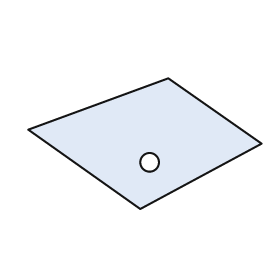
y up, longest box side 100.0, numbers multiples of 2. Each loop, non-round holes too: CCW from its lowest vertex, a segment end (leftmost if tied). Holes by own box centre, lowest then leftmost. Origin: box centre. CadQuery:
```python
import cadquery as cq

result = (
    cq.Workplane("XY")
    .moveTo(-2.0, -28.0)
    .lineTo(50.0, 0.0)
    .lineTo(10.0, 28.0)
    .lineTo(-50.0, 6.0)
    .close()
    .moveTo(2.0, -8.0)
    .circle(4.0)
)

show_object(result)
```